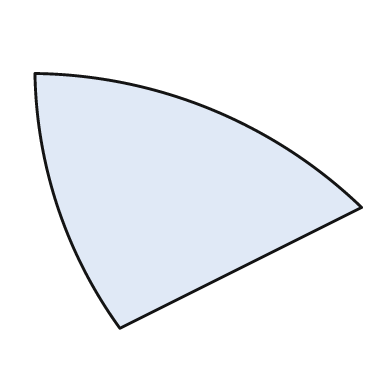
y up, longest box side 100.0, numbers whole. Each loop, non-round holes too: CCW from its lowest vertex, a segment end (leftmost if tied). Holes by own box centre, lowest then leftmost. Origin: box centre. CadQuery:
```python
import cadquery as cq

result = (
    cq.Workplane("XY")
    .moveTo(-24.0, -39.0)
    .lineTo(50.0, -2.0)
    .threePointArc((4.0, 28.0), (-50.0, 39.0))
    .threePointArc((-43.0, -2.0), (-24.0, -39.0))
    .close()
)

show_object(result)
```